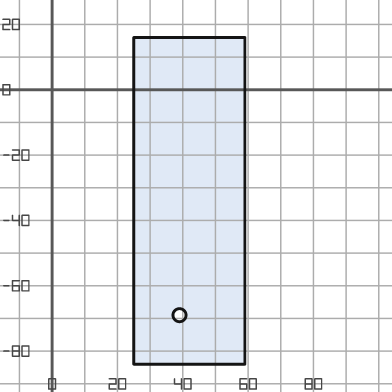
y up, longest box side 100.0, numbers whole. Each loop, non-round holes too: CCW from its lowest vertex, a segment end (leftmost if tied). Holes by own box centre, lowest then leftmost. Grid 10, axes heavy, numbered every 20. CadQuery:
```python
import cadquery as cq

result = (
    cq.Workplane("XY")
    .moveTo(25.0, -84.0)
    .lineTo(59.0, -84.0)
    .lineTo(59.0, 16.0)
    .lineTo(25.0, 16.0)
    .close()
    .moveTo(39.0, -69.0)
    .circle(2.0)
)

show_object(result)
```